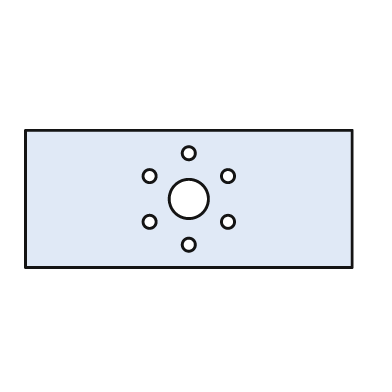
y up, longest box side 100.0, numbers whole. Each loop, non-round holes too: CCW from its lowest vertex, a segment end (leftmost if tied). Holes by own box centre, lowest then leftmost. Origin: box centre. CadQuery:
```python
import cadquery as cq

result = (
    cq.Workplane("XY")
    .moveTo(-50.0, -21.0)
    .lineTo(50.0, -21.0)
    .lineTo(50.0, 21.0)
    .lineTo(-50.0, 21.0)
    .close()
    .moveTo(0.0, -14.0)
    .circle(2.0)
    .moveTo(-12.0, -7.0)
    .circle(2.0)
    .moveTo(12.0, -7.0)
    .circle(2.0)
    .moveTo(0.0, 0.0)
    .circle(6.0)
    .moveTo(-12.0, 7.0)
    .circle(2.0)
    .moveTo(12.0, 7.0)
    .circle(2.0)
    .moveTo(0.0, 14.0)
    .circle(2.0)
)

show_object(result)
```